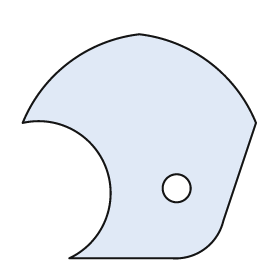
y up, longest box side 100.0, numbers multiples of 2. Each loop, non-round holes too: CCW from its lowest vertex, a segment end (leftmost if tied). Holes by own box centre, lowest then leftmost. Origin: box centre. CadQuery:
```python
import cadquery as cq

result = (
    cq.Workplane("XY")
    .moveTo(-30.0, -48.0)
    .lineTo(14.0, -48.0)
    .threePointArc((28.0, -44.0), (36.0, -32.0))
    .lineTo(50.0, 10.0)
    .threePointArc((30.0, 36.0), (0.0, 48.0))
    .threePointArc((-30.0, 36.0), (-50.0, 10.0))
    .threePointArc((-14.0, -10.0), (-30.0, -48.0))
    .close()
    .moveTo(16.0, -18.0)
    .circle(6.0)
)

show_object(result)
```